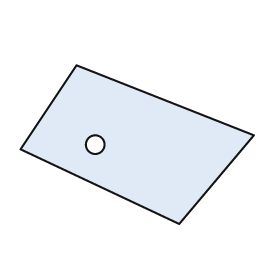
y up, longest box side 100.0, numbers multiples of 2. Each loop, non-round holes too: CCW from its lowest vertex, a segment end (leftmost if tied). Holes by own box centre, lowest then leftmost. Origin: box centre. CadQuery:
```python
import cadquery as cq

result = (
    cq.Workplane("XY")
    .moveTo(18.0, -34.0)
    .lineTo(50.0, 4.0)
    .lineTo(-26.0, 34.0)
    .lineTo(-50.0, -2.0)
    .close()
    .moveTo(-18.0, 0.0)
    .circle(4.0)
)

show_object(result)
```